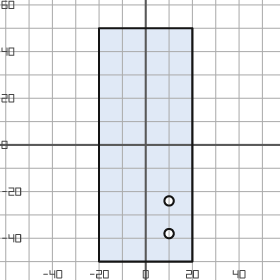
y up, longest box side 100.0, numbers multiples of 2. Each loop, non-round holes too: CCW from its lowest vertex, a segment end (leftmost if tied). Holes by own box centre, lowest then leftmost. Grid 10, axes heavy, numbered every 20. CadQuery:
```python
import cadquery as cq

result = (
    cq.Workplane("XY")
    .moveTo(-20.0, -50.0)
    .lineTo(20.0, -50.0)
    .lineTo(20.0, 50.0)
    .lineTo(-20.0, 50.0)
    .close()
    .moveTo(10.0, -38.0)
    .circle(2.0)
    .moveTo(10.0, -24.0)
    .circle(2.0)
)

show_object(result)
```